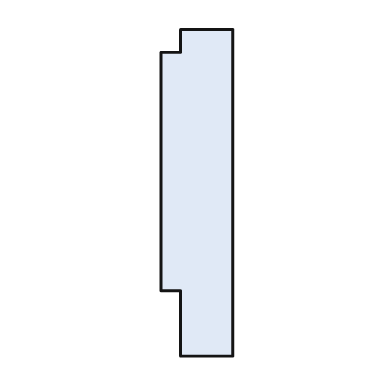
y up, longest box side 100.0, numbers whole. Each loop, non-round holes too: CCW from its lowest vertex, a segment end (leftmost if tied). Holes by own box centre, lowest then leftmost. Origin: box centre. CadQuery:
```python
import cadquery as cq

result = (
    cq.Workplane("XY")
    .moveTo(-5.0, -50.0)
    .lineTo(11.0, -50.0)
    .lineTo(11.0, 50.0)
    .lineTo(-5.0, 50.0)
    .lineTo(-5.0, 43.0)
    .lineTo(-11.0, 43.0)
    .lineTo(-11.0, -30.0)
    .lineTo(-5.0, -30.0)
    .close()
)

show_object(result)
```